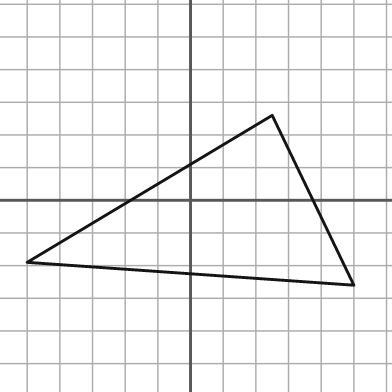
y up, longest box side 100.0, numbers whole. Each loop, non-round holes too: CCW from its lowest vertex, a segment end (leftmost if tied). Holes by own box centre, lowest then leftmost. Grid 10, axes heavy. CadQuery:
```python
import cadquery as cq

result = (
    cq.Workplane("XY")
    .moveTo(50.0, -26.0)
    .lineTo(25.0, 26.0)
    .lineTo(-50.0, -19.0)
    .close()
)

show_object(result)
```